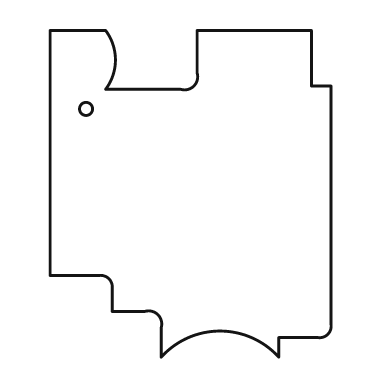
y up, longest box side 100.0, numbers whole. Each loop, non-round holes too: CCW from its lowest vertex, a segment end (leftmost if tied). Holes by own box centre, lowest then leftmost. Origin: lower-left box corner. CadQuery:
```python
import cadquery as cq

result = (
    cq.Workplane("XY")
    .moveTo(34.0, 0.0)
    .threePointArc((52.0, 8.0), (70.0, 0.0))
    .lineTo(70.0, 6.0)
    .lineTo(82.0, 6.0)
    .threePointArc((85.0, 7.0), (86.0, 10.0))
    .lineTo(86.0, 83.0)
    .lineTo(80.0, 83.0)
    .lineTo(80.0, 100.0)
    .lineTo(45.0, 100.0)
    .lineTo(45.0, 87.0)
    .threePointArc((44.0, 83.0), (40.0, 82.0))
    .lineTo(17.0, 82.0)
    .threePointArc((20.0, 91.0), (17.0, 100.0))
    .lineTo(0.0, 100.0)
    .lineTo(0.0, 25.0)
    .lineTo(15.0, 25.0)
    .threePointArc((18.0, 24.0), (19.0, 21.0))
    .lineTo(19.0, 14.0)
    .lineTo(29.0, 14.0)
    .threePointArc((33.0, 13.0), (34.0, 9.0))
    .close()
    .moveTo(11.0, 76.0)
    .circle(2.0)
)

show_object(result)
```